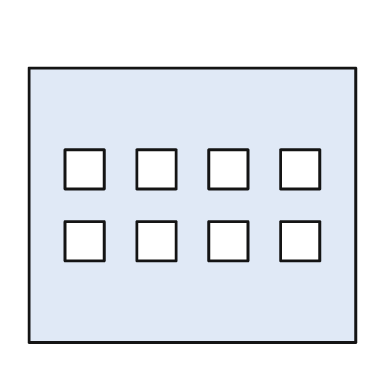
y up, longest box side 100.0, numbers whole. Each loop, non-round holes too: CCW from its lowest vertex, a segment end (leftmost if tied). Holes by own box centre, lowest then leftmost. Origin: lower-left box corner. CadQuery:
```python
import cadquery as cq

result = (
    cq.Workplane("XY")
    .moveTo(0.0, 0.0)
    .lineTo(100.0, 0.0)
    .lineTo(100.0, 84.0)
    .lineTo(0.0, 84.0)
    .close()
    .moveTo(11.0, 25.0)
    .lineTo(23.0, 25.0)
    .lineTo(23.0, 37.0)
    .lineTo(11.0, 37.0)
    .close()
    .moveTo(33.0, 25.0)
    .lineTo(45.0, 25.0)
    .lineTo(45.0, 37.0)
    .lineTo(33.0, 37.0)
    .close()
    .moveTo(55.0, 25.0)
    .lineTo(67.0, 25.0)
    .lineTo(67.0, 37.0)
    .lineTo(55.0, 37.0)
    .close()
    .moveTo(77.0, 25.0)
    .lineTo(89.0, 25.0)
    .lineTo(89.0, 37.0)
    .lineTo(77.0, 37.0)
    .close()
    .moveTo(11.0, 47.0)
    .lineTo(23.0, 47.0)
    .lineTo(23.0, 59.0)
    .lineTo(11.0, 59.0)
    .close()
    .moveTo(33.0, 47.0)
    .lineTo(45.0, 47.0)
    .lineTo(45.0, 59.0)
    .lineTo(33.0, 59.0)
    .close()
    .moveTo(55.0, 47.0)
    .lineTo(67.0, 47.0)
    .lineTo(67.0, 59.0)
    .lineTo(55.0, 59.0)
    .close()
    .moveTo(77.0, 47.0)
    .lineTo(89.0, 47.0)
    .lineTo(89.0, 59.0)
    .lineTo(77.0, 59.0)
    .close()
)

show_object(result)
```